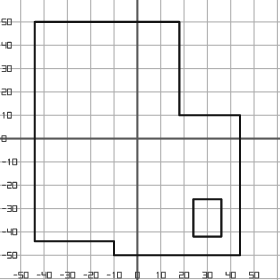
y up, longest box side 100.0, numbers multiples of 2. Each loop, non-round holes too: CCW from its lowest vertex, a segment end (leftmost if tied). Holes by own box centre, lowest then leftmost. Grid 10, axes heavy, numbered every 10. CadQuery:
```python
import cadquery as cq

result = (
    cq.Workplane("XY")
    .moveTo(-10.0, -50.0)
    .lineTo(44.0, -50.0)
    .lineTo(44.0, 10.0)
    .lineTo(18.0, 10.0)
    .lineTo(18.0, 50.0)
    .lineTo(-44.0, 50.0)
    .lineTo(-44.0, -44.0)
    .lineTo(-10.0, -44.0)
    .close()
    .moveTo(24.0, -42.0)
    .lineTo(36.0, -42.0)
    .lineTo(36.0, -26.0)
    .lineTo(24.0, -26.0)
    .close()
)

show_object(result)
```